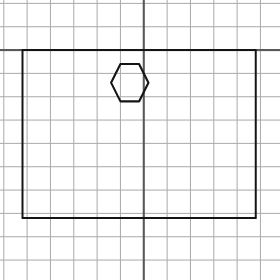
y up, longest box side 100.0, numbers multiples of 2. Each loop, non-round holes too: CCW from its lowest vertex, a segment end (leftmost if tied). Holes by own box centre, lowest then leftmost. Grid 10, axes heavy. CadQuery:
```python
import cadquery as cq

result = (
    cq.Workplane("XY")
    .moveTo(-52.0, -72.0)
    .lineTo(48.0, -72.0)
    .lineTo(48.0, 0.0)
    .lineTo(-52.0, 0.0)
    .close()
    .moveTo(-10.0, -22.0)
    .lineTo(-2.0, -22.0)
    .lineTo(2.0, -14.0)
    .lineTo(-2.0, -6.0)
    .lineTo(-10.0, -6.0)
    .lineTo(-14.0, -14.0)
    .close()
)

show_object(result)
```